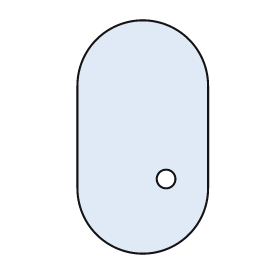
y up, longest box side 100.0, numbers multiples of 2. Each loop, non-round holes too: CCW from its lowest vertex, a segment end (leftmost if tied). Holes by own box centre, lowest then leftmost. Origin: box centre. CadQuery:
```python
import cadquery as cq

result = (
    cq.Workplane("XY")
    .moveTo(-28.0, -22.0)
    .threePointArc((0.0, -50.0), (28.0, -22.0))
    .lineTo(28.0, 22.0)
    .threePointArc((0.0, 50.0), (-28.0, 22.0))
    .close()
    .moveTo(10.0, -18.0)
    .circle(4.0)
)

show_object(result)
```